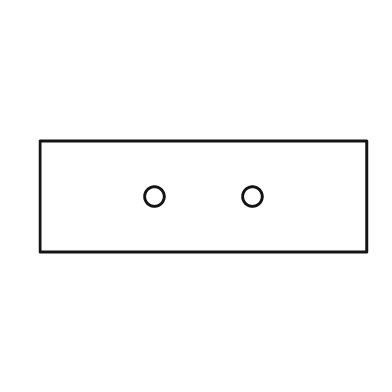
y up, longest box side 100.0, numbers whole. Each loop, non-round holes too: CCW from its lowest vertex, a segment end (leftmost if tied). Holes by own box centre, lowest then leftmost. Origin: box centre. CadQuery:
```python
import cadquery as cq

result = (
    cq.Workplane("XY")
    .moveTo(-50.0, -17.0)
    .lineTo(50.0, -17.0)
    .lineTo(50.0, 17.0)
    .lineTo(-50.0, 17.0)
    .close()
    .moveTo(-15.0, 0.0)
    .circle(3.0)
    .moveTo(15.0, 0.0)
    .circle(3.0)
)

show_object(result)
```